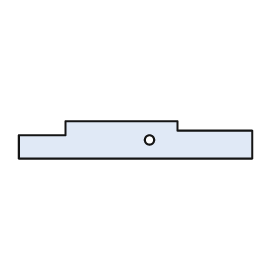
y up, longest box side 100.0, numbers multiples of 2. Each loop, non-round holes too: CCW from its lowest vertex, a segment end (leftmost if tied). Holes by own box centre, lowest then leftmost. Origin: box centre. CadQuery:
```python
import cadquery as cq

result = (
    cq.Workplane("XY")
    .moveTo(-50.0, -8.0)
    .lineTo(50.0, -8.0)
    .lineTo(50.0, 4.0)
    .lineTo(18.0, 4.0)
    .lineTo(18.0, 8.0)
    .lineTo(-30.0, 8.0)
    .lineTo(-30.0, 2.0)
    .lineTo(-50.0, 2.0)
    .close()
    .moveTo(6.0, 0.0)
    .circle(2.0)
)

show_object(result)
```